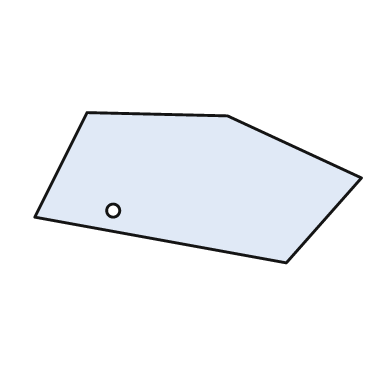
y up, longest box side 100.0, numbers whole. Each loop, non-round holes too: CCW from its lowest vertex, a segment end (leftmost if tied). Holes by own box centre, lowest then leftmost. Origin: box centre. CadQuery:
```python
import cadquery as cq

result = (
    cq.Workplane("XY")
    .moveTo(27.0, -23.0)
    .lineTo(50.0, 3.0)
    .lineTo(9.0, 22.0)
    .lineTo(-34.0, 23.0)
    .lineTo(-50.0, -9.0)
    .close()
    .moveTo(-26.0, -7.0)
    .circle(2.0)
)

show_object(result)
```